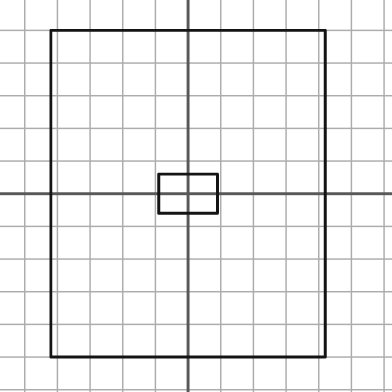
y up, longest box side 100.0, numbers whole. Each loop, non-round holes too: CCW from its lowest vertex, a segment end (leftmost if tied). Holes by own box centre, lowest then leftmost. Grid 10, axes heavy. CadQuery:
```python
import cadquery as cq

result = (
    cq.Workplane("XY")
    .moveTo(-42.0, -50.0)
    .lineTo(42.0, -50.0)
    .lineTo(42.0, 50.0)
    .lineTo(-42.0, 50.0)
    .close()
    .moveTo(-9.0, -6.0)
    .lineTo(9.0, -6.0)
    .lineTo(9.0, 6.0)
    .lineTo(-9.0, 6.0)
    .close()
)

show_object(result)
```